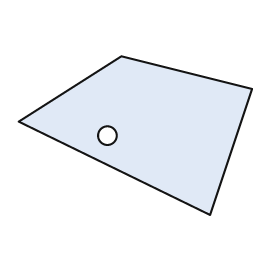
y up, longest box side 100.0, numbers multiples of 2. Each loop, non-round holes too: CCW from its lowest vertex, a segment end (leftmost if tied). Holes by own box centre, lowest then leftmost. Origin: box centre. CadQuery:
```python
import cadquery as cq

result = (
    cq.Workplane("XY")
    .moveTo(32.0, -34.0)
    .lineTo(50.0, 20.0)
    .lineTo(-6.0, 34.0)
    .lineTo(-50.0, 6.0)
    .close()
    .moveTo(-12.0, 0.0)
    .circle(4.0)
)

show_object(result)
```